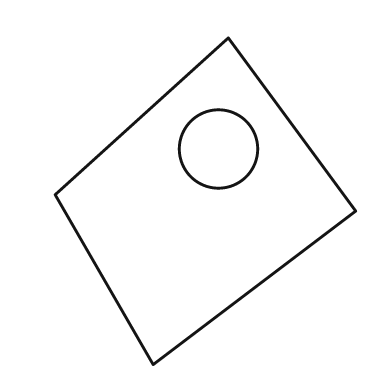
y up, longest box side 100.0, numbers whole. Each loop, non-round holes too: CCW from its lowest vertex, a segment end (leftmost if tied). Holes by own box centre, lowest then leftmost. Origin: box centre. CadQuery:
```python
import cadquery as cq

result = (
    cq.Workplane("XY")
    .moveTo(-16.0, -50.0)
    .lineTo(46.0, -3.0)
    .lineTo(7.0, 50.0)
    .lineTo(-46.0, 2.0)
    .close()
    .moveTo(4.0, 16.0)
    .circle(12.0)
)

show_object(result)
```